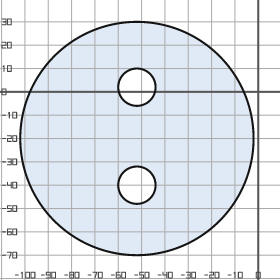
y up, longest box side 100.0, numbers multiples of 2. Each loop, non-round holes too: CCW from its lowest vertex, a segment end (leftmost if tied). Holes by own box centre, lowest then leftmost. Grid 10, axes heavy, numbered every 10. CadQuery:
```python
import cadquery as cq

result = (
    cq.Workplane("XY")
    .moveTo(-52.0, -20.0)
    .circle(50.0)
    .moveTo(-52.0, -40.0)
    .circle(8.0)
    .moveTo(-52.0, 2.0)
    .circle(8.0)
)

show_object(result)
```